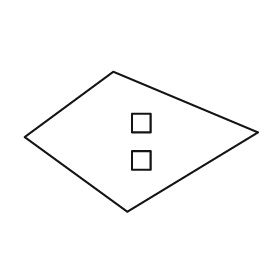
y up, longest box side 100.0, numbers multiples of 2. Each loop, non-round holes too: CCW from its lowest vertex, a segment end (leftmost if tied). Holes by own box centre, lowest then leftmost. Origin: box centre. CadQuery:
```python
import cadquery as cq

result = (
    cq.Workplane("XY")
    .moveTo(-6.0, -30.0)
    .lineTo(50.0, 4.0)
    .lineTo(-12.0, 30.0)
    .lineTo(-50.0, 2.0)
    .close()
    .moveTo(-4.0, -12.0)
    .lineTo(4.0, -12.0)
    .lineTo(4.0, -4.0)
    .lineTo(-4.0, -4.0)
    .close()
    .moveTo(-4.0, 4.0)
    .lineTo(4.0, 4.0)
    .lineTo(4.0, 12.0)
    .lineTo(-4.0, 12.0)
    .close()
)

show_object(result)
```